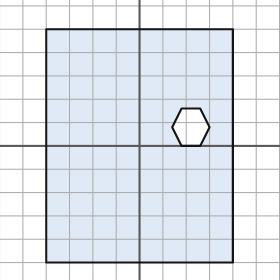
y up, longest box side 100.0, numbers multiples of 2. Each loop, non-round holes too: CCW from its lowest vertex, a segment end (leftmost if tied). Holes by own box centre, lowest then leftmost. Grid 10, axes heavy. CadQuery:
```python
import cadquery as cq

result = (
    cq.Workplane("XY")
    .moveTo(-40.0, -50.0)
    .lineTo(40.0, -50.0)
    .lineTo(40.0, 50.0)
    .lineTo(-40.0, 50.0)
    .close()
    .moveTo(18.0, 0.0)
    .lineTo(26.0, 0.0)
    .lineTo(30.0, 8.0)
    .lineTo(26.0, 16.0)
    .lineTo(18.0, 16.0)
    .lineTo(14.0, 8.0)
    .close()
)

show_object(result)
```